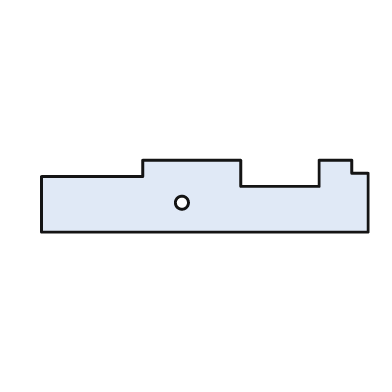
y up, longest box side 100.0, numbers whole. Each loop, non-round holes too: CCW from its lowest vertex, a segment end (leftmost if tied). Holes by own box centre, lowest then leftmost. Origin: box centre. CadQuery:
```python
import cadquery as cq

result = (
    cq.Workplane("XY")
    .moveTo(-50.0, -11.0)
    .lineTo(50.0, -11.0)
    .lineTo(50.0, 7.0)
    .lineTo(45.0, 7.0)
    .lineTo(45.0, 11.0)
    .lineTo(35.0, 11.0)
    .lineTo(35.0, 3.0)
    .lineTo(11.0, 3.0)
    .lineTo(11.0, 11.0)
    .lineTo(-19.0, 11.0)
    .lineTo(-19.0, 6.0)
    .lineTo(-50.0, 6.0)
    .close()
    .moveTo(-7.0, -2.0)
    .circle(2.0)
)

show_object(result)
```